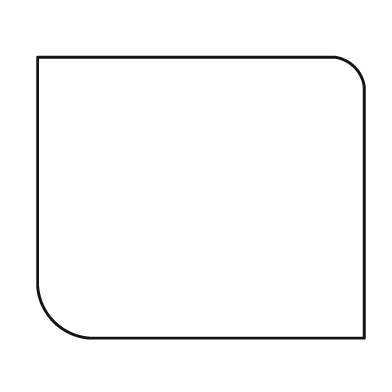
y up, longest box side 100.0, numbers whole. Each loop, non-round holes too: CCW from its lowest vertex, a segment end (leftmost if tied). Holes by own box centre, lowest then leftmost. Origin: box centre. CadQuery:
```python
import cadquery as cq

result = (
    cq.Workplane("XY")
    .moveTo(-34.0, -43.0)
    .lineTo(50.0, -43.0)
    .lineTo(50.0, 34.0)
    .threePointArc((47.0, 40.0), (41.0, 43.0))
    .lineTo(-50.0, 43.0)
    .lineTo(-50.0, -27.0)
    .threePointArc((-45.0, -38.0), (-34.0, -43.0))
    .close()
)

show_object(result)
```